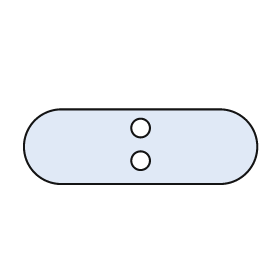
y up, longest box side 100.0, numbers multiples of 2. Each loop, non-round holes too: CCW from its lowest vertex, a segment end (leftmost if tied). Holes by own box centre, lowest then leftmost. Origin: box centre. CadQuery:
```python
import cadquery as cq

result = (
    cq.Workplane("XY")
    .moveTo(-34.0, -16.0)
    .lineTo(34.0, -16.0)
    .threePointArc((50.0, 0.0), (34.0, 16.0))
    .lineTo(-34.0, 16.0)
    .threePointArc((-50.0, 0.0), (-34.0, -16.0))
    .close()
    .moveTo(0.0, -6.0)
    .circle(4.0)
    .moveTo(0.0, 8.0)
    .circle(4.0)
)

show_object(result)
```